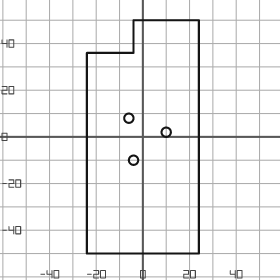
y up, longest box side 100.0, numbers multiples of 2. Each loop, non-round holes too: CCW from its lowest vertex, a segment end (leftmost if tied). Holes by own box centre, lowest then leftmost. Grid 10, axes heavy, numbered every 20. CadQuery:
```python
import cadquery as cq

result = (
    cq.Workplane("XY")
    .moveTo(-24.0, -50.0)
    .lineTo(24.0, -50.0)
    .lineTo(24.0, 50.0)
    .lineTo(-4.0, 50.0)
    .lineTo(-4.0, 36.0)
    .lineTo(-24.0, 36.0)
    .close()
    .moveTo(-4.0, -10.0)
    .circle(2.0)
    .moveTo(10.0, 2.0)
    .circle(2.0)
    .moveTo(-6.0, 8.0)
    .circle(2.0)
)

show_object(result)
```